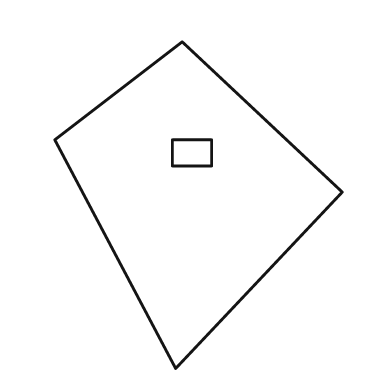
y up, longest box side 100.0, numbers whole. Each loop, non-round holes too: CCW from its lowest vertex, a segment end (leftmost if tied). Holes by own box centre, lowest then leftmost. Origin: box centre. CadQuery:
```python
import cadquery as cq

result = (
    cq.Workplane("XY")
    .moveTo(-7.0, -50.0)
    .lineTo(44.0, 4.0)
    .lineTo(-5.0, 50.0)
    .lineTo(-44.0, 20.0)
    .close()
    .moveTo(-8.0, 12.0)
    .lineTo(4.0, 12.0)
    .lineTo(4.0, 20.0)
    .lineTo(-8.0, 20.0)
    .close()
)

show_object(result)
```